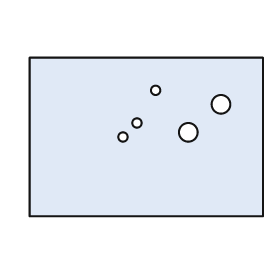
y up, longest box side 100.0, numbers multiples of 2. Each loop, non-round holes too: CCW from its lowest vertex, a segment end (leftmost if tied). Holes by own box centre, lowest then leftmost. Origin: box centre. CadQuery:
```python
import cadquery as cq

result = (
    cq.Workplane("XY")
    .moveTo(-50.0, -34.0)
    .lineTo(50.0, -34.0)
    .lineTo(50.0, 34.0)
    .lineTo(-50.0, 34.0)
    .close()
    .moveTo(-10.0, 0.0)
    .circle(2.0)
    .moveTo(18.0, 2.0)
    .circle(4.0)
    .moveTo(-4.0, 6.0)
    .circle(2.0)
    .moveTo(32.0, 14.0)
    .circle(4.0)
    .moveTo(4.0, 20.0)
    .circle(2.0)
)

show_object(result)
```